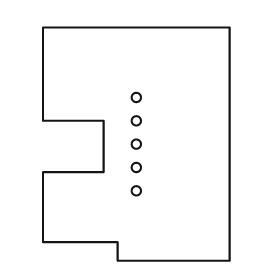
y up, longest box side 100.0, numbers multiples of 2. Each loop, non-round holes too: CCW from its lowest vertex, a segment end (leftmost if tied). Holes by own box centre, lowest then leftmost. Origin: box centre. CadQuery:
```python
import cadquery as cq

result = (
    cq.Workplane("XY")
    .moveTo(-8.0, -50.0)
    .lineTo(40.0, -50.0)
    .lineTo(40.0, 50.0)
    .lineTo(-40.0, 50.0)
    .lineTo(-40.0, 10.0)
    .lineTo(-14.0, 10.0)
    .lineTo(-14.0, -12.0)
    .lineTo(-40.0, -12.0)
    .lineTo(-40.0, -42.0)
    .lineTo(-8.0, -42.0)
    .close()
    .moveTo(0.0, -20.0)
    .circle(2.0)
    .moveTo(0.0, -10.0)
    .circle(2.0)
    .moveTo(0.0, 0.0)
    .circle(2.0)
    .moveTo(0.0, 10.0)
    .circle(2.0)
    .moveTo(0.0, 20.0)
    .circle(2.0)
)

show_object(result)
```